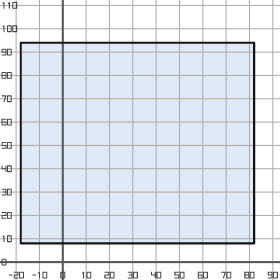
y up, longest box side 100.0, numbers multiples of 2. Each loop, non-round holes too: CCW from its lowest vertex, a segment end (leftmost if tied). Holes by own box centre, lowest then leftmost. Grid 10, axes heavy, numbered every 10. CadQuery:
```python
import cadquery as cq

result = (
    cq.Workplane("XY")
    .moveTo(-18.0, 8.0)
    .lineTo(82.0, 8.0)
    .lineTo(82.0, 94.0)
    .lineTo(-18.0, 94.0)
    .close()
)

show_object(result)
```